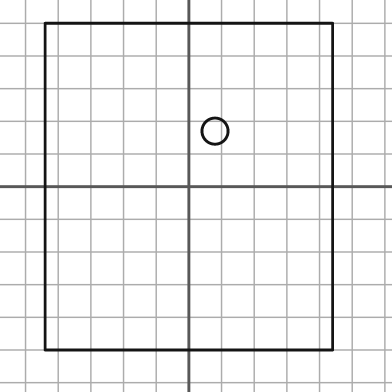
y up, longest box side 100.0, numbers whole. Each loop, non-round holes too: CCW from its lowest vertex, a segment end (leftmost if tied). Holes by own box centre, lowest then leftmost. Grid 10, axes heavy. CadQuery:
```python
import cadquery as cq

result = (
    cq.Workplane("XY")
    .moveTo(-44.0, -50.0)
    .lineTo(44.0, -50.0)
    .lineTo(44.0, 50.0)
    .lineTo(-44.0, 50.0)
    .close()
    .moveTo(8.0, 17.0)
    .circle(4.0)
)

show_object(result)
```